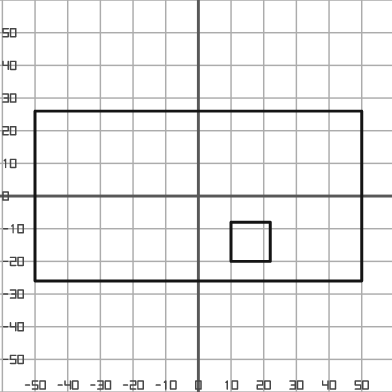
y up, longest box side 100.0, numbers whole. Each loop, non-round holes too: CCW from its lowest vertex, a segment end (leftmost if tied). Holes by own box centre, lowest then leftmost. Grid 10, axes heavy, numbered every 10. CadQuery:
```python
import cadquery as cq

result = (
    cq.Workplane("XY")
    .moveTo(-50.0, -26.0)
    .lineTo(50.0, -26.0)
    .lineTo(50.0, 26.0)
    .lineTo(-50.0, 26.0)
    .close()
    .moveTo(10.0, -20.0)
    .lineTo(22.0, -20.0)
    .lineTo(22.0, -8.0)
    .lineTo(10.0, -8.0)
    .close()
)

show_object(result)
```